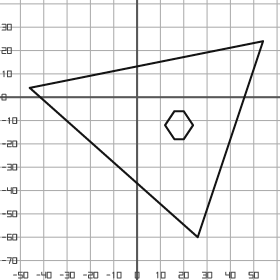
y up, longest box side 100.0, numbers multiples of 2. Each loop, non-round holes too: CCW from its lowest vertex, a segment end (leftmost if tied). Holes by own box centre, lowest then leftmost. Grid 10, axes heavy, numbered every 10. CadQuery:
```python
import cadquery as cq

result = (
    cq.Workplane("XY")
    .moveTo(26.0, -60.0)
    .lineTo(54.0, 24.0)
    .lineTo(-46.0, 4.0)
    .close()
    .moveTo(16.0, -18.0)
    .lineTo(20.0, -18.0)
    .lineTo(24.0, -12.0)
    .lineTo(20.0, -6.0)
    .lineTo(16.0, -6.0)
    .lineTo(12.0, -12.0)
    .close()
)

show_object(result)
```